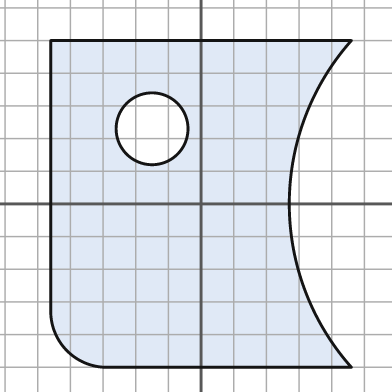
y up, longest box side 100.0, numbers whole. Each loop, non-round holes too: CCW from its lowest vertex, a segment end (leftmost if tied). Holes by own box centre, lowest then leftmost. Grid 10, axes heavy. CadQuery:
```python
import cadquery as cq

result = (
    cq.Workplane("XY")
    .moveTo(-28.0, -50.0)
    .lineTo(46.0, -50.0)
    .threePointArc((27.0, 0.0), (46.0, 50.0))
    .lineTo(-46.0, 50.0)
    .lineTo(-46.0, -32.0)
    .threePointArc((-41.0, -45.0), (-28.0, -50.0))
    .close()
    .moveTo(-15.0, 23.0)
    .circle(11.0)
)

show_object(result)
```